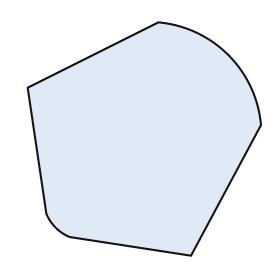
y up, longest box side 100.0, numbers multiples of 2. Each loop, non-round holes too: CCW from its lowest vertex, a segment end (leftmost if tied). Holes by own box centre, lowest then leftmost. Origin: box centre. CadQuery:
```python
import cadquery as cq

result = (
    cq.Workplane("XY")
    .moveTo(20.0, -50.0)
    .lineTo(50.0, 6.0)
    .threePointArc((36.0, 36.0), (6.0, 50.0))
    .lineTo(-50.0, 22.0)
    .lineTo(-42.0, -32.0)
    .threePointArc((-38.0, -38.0), (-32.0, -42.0))
    .close()
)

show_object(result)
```